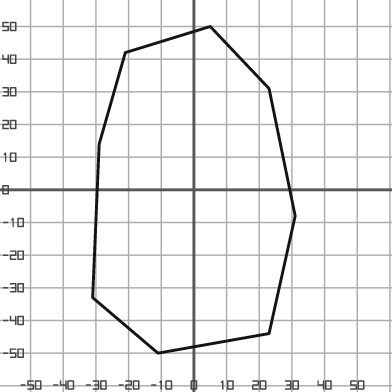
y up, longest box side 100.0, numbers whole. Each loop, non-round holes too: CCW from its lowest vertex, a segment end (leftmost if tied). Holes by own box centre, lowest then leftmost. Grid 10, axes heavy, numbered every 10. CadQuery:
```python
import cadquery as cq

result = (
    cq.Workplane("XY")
    .moveTo(-11.0, -50.0)
    .lineTo(23.0, -44.0)
    .lineTo(31.0, -8.0)
    .lineTo(23.0, 31.0)
    .lineTo(5.0, 50.0)
    .lineTo(-21.0, 42.0)
    .lineTo(-29.0, 14.0)
    .lineTo(-31.0, -33.0)
    .close()
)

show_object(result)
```